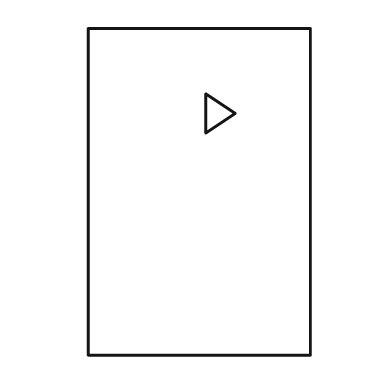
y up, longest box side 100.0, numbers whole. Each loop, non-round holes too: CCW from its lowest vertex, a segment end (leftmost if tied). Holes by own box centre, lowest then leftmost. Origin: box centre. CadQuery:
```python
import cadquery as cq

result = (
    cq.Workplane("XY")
    .moveTo(-34.0, -50.0)
    .lineTo(34.0, -50.0)
    .lineTo(34.0, 50.0)
    .lineTo(-34.0, 50.0)
    .close()
    .moveTo(2.0, 18.0)
    .lineTo(11.0, 24.0)
    .lineTo(2.0, 30.0)
    .close()
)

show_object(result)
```